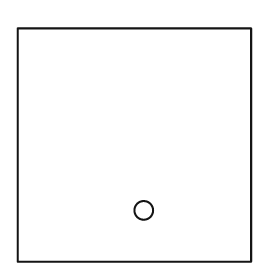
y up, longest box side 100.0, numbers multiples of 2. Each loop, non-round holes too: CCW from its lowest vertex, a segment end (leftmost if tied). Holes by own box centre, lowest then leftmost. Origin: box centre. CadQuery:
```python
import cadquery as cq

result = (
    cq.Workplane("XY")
    .moveTo(-50.0, -50.0)
    .lineTo(50.0, -50.0)
    .lineTo(50.0, 50.0)
    .lineTo(-50.0, 50.0)
    .close()
    .moveTo(4.0, -28.0)
    .circle(4.0)
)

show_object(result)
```